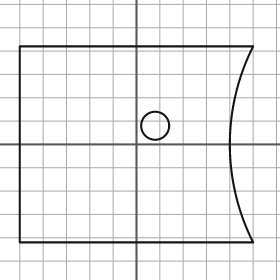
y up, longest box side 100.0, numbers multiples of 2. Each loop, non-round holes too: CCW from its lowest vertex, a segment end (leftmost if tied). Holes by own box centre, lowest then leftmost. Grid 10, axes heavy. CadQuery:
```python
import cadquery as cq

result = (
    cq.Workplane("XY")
    .moveTo(-50.0, -42.0)
    .lineTo(50.0, -42.0)
    .threePointArc((40.0, 0.0), (50.0, 42.0))
    .lineTo(-50.0, 42.0)
    .close()
    .moveTo(8.0, 8.0)
    .circle(6.0)
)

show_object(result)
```